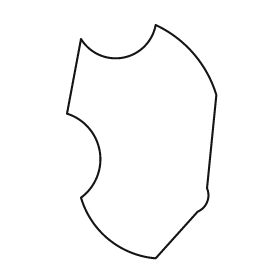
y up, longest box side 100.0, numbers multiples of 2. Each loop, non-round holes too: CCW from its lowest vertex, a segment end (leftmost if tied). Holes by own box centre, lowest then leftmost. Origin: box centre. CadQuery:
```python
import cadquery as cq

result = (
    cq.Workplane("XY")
    .moveTo(6.0, -50.0)
    .lineTo(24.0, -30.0)
    .threePointArc((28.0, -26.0), (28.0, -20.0))
    .lineTo(32.0, 20.0)
    .threePointArc((22.0, 38.0), (6.0, 50.0))
    .threePointArc((-8.0, 36.0), (-26.0, 44.0))
    .lineTo(-32.0, 12.0)
    .threePointArc((-18.0, -4.0), (-26.0, -24.0))
    .threePointArc((-14.0, -42.0), (6.0, -50.0))
    .close()
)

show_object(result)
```